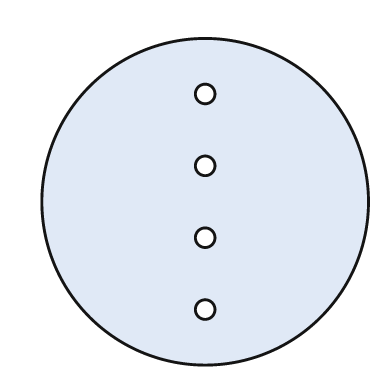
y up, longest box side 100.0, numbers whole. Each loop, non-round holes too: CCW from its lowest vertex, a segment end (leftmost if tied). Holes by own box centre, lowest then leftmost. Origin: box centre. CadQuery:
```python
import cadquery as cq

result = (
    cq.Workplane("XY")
    .moveTo(0.0, 0.0)
    .circle(50.0)
    .moveTo(0.0, -33.0)
    .circle(3.0)
    .moveTo(0.0, -11.0)
    .circle(3.0)
    .moveTo(0.0, 11.0)
    .circle(3.0)
    .moveTo(0.0, 33.0)
    .circle(3.0)
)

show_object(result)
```